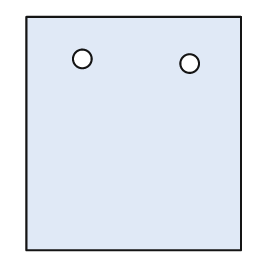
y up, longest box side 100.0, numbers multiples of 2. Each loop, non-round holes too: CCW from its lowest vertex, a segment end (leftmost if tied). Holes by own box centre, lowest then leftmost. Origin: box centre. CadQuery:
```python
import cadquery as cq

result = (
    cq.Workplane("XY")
    .moveTo(-46.0, -50.0)
    .lineTo(46.0, -50.0)
    .lineTo(46.0, 50.0)
    .lineTo(-46.0, 50.0)
    .close()
    .moveTo(24.0, 30.0)
    .circle(4.0)
    .moveTo(-22.0, 32.0)
    .circle(4.0)
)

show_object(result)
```